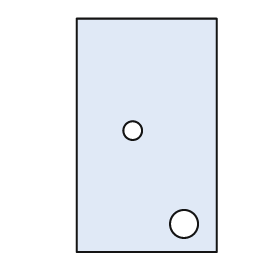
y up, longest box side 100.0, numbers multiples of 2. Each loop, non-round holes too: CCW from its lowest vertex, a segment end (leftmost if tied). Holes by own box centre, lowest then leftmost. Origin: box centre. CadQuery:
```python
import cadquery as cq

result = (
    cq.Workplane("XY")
    .moveTo(-30.0, -50.0)
    .lineTo(30.0, -50.0)
    .lineTo(30.0, 50.0)
    .lineTo(-30.0, 50.0)
    .close()
    .moveTo(16.0, -38.0)
    .circle(6.0)
    .moveTo(-6.0, 2.0)
    .circle(4.0)
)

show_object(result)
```